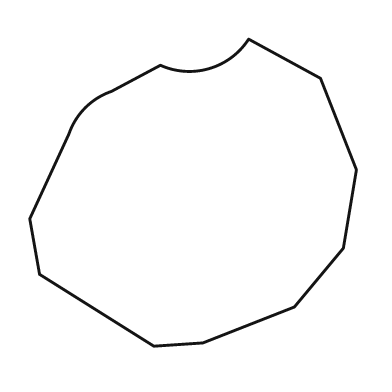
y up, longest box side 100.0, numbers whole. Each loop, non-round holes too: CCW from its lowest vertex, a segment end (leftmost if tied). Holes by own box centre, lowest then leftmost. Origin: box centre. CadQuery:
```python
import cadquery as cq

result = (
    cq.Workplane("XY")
    .moveTo(-12.0, -47.0)
    .lineTo(3.0, -46.0)
    .lineTo(31.0, -35.0)
    .lineTo(46.0, -17.0)
    .lineTo(50.0, 7.0)
    .lineTo(39.0, 35.0)
    .lineTo(17.0, 47.0)
    .threePointArc((5.0, 38.0), (-10.0, 39.0))
    .lineTo(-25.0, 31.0)
    .threePointArc((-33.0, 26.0), (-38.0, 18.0))
    .lineTo(-50.0, -8.0)
    .lineTo(-47.0, -25.0)
    .close()
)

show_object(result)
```